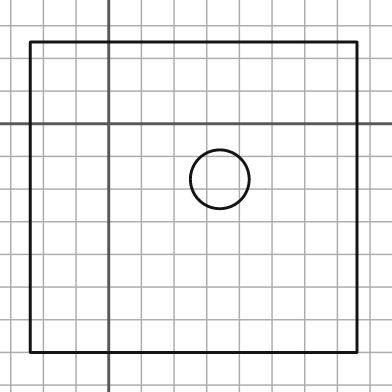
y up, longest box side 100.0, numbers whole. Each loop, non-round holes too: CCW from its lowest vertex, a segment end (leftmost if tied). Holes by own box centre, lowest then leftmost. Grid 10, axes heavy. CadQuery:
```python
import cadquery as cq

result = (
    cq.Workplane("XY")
    .moveTo(-24.0, -70.0)
    .lineTo(76.0, -70.0)
    .lineTo(76.0, 25.0)
    .lineTo(-24.0, 25.0)
    .close()
    .moveTo(34.0, -17.0)
    .circle(9.0)
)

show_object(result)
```